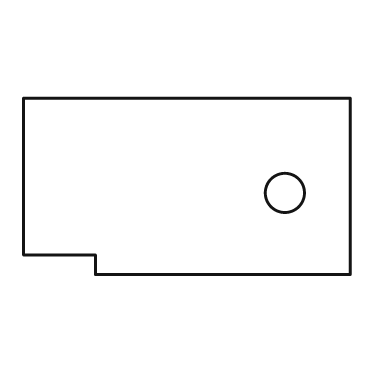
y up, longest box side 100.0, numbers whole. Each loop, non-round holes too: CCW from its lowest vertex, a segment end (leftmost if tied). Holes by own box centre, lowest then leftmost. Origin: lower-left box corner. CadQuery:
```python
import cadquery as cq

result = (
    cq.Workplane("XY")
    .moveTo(22.0, 0.0)
    .lineTo(100.0, 0.0)
    .lineTo(100.0, 54.0)
    .lineTo(0.0, 54.0)
    .lineTo(0.0, 6.0)
    .lineTo(22.0, 6.0)
    .close()
    .moveTo(80.0, 25.0)
    .circle(6.0)
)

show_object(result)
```